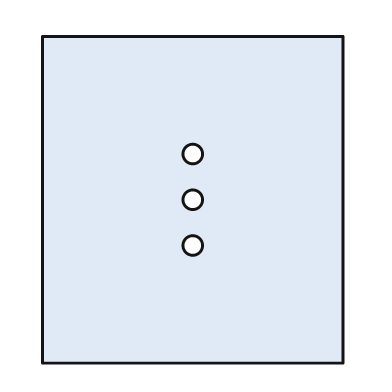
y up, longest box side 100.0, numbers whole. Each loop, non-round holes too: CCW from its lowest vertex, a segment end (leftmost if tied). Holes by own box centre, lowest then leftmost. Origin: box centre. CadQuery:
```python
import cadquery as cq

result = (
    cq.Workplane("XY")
    .moveTo(-46.0, -50.0)
    .lineTo(46.0, -50.0)
    .lineTo(46.0, 50.0)
    .lineTo(-46.0, 50.0)
    .close()
    .moveTo(0.0, -14.0)
    .circle(3.0)
    .moveTo(0.0, 0.0)
    .circle(3.0)
    .moveTo(0.0, 14.0)
    .circle(3.0)
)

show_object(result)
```